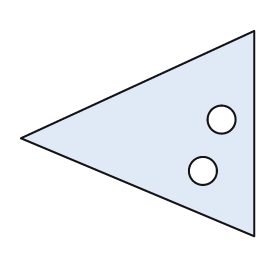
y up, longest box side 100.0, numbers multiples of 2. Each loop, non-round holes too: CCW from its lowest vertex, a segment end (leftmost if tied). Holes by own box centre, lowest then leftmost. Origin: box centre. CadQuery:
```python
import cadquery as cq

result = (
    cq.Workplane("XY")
    .moveTo(50.0, -44.0)
    .lineTo(50.0, 44.0)
    .lineTo(-50.0, -2.0)
    .close()
    .moveTo(28.0, -16.0)
    .circle(6.0)
    .moveTo(36.0, 6.0)
    .circle(6.0)
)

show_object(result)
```